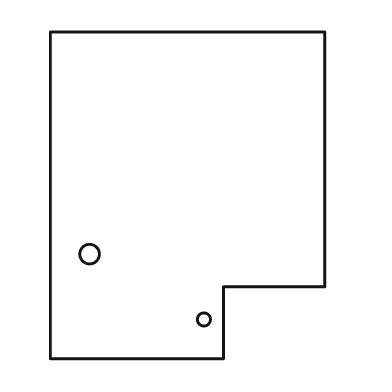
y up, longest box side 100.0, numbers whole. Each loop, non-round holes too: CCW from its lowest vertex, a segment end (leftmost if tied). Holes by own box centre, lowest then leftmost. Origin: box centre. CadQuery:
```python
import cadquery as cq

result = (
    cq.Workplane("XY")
    .moveTo(-42.0, -50.0)
    .lineTo(11.0, -50.0)
    .lineTo(11.0, -28.0)
    .lineTo(42.0, -28.0)
    .lineTo(42.0, 50.0)
    .lineTo(-42.0, 50.0)
    .close()
    .moveTo(5.0, -38.0)
    .circle(2.0)
    .moveTo(-30.0, -18.0)
    .circle(3.0)
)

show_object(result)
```